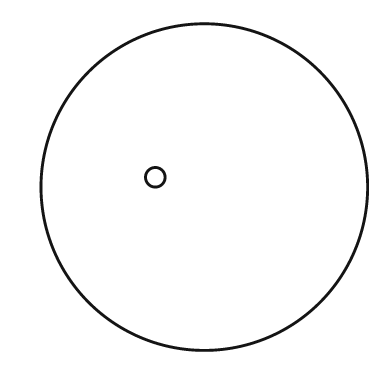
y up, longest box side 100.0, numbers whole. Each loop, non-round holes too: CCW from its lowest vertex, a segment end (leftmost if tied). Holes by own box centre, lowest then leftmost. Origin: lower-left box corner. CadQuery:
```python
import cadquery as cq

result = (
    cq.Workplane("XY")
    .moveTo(50.0, 50.0)
    .circle(50.0)
    .moveTo(35.0, 53.0)
    .circle(3.0)
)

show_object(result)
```